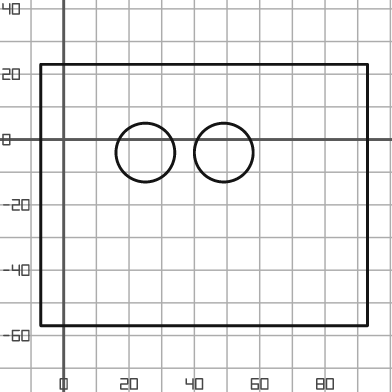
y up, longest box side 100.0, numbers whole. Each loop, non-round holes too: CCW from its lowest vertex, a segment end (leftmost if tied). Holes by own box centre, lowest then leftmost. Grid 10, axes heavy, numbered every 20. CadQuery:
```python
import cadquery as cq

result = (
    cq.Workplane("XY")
    .moveTo(-7.0, -57.0)
    .lineTo(93.0, -57.0)
    .lineTo(93.0, 23.0)
    .lineTo(-7.0, 23.0)
    .close()
    .moveTo(25.0, -4.0)
    .circle(9.0)
    .moveTo(49.0, -4.0)
    .circle(9.0)
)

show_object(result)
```